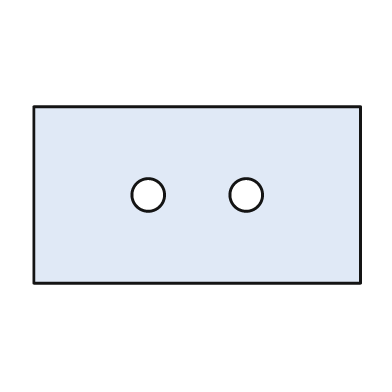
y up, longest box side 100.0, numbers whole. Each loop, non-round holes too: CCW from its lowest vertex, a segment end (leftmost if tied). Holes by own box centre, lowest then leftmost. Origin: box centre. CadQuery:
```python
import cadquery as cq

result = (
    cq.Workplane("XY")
    .moveTo(-50.0, -27.0)
    .lineTo(50.0, -27.0)
    .lineTo(50.0, 27.0)
    .lineTo(-50.0, 27.0)
    .close()
    .moveTo(-15.0, 0.0)
    .circle(5.0)
    .moveTo(15.0, 0.0)
    .circle(5.0)
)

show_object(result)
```